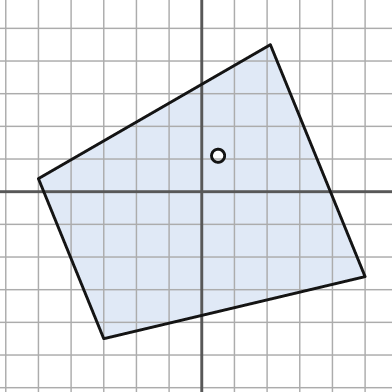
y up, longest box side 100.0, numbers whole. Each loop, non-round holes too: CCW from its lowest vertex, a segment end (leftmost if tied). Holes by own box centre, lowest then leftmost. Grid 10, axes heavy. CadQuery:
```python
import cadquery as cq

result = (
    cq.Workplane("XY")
    .moveTo(-30.0, -45.0)
    .lineTo(50.0, -26.0)
    .lineTo(21.0, 45.0)
    .lineTo(-50.0, 4.0)
    .close()
    .moveTo(5.0, 11.0)
    .circle(2.0)
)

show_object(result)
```